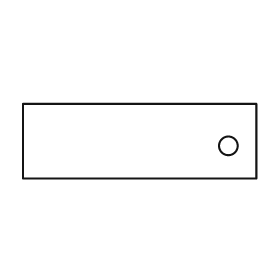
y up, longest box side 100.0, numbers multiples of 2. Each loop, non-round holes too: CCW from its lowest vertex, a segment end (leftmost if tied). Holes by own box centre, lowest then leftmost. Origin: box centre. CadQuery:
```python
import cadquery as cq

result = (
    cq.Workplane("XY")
    .moveTo(-50.0, -16.0)
    .lineTo(50.0, -16.0)
    .lineTo(50.0, 16.0)
    .lineTo(-50.0, 16.0)
    .close()
    .moveTo(38.0, -2.0)
    .circle(4.0)
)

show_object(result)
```